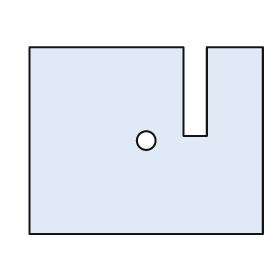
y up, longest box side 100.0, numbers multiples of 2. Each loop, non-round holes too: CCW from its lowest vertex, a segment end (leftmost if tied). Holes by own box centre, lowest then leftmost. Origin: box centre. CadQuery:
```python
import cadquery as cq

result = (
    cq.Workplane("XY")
    .moveTo(-50.0, -40.0)
    .lineTo(50.0, -40.0)
    .lineTo(50.0, 40.0)
    .lineTo(26.0, 40.0)
    .lineTo(26.0, 2.0)
    .lineTo(16.0, 2.0)
    .lineTo(16.0, 40.0)
    .lineTo(-50.0, 40.0)
    .close()
    .moveTo(0.0, 0.0)
    .circle(4.0)
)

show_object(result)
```